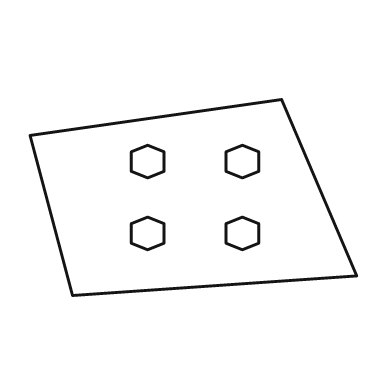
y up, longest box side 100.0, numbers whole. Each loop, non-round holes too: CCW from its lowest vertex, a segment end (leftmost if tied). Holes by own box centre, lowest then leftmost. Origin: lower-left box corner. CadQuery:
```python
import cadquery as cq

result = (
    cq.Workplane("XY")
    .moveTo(13.0, 0.0)
    .lineTo(100.0, 6.0)
    .lineTo(77.0, 60.0)
    .lineTo(0.0, 49.0)
    .close()
    .moveTo(36.0, 14.0)
    .lineTo(41.0, 16.0)
    .lineTo(41.0, 22.0)
    .lineTo(36.0, 24.0)
    .lineTo(31.0, 22.0)
    .lineTo(31.0, 16.0)
    .close()
    .moveTo(65.0, 14.0)
    .lineTo(70.0, 16.0)
    .lineTo(70.0, 22.0)
    .lineTo(65.0, 24.0)
    .lineTo(60.0, 22.0)
    .lineTo(60.0, 16.0)
    .close()
    .moveTo(36.0, 36.0)
    .lineTo(41.0, 38.0)
    .lineTo(41.0, 44.0)
    .lineTo(36.0, 46.0)
    .lineTo(31.0, 44.0)
    .lineTo(31.0, 38.0)
    .close()
    .moveTo(65.0, 36.0)
    .lineTo(70.0, 38.0)
    .lineTo(70.0, 44.0)
    .lineTo(65.0, 46.0)
    .lineTo(60.0, 44.0)
    .lineTo(60.0, 38.0)
    .close()
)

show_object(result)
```